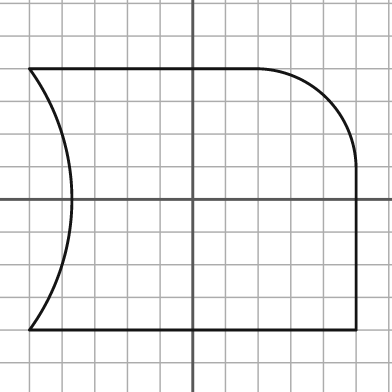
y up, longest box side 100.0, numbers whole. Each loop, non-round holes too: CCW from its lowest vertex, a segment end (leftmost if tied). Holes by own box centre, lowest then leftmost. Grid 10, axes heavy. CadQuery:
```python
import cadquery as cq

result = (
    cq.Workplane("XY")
    .moveTo(-50.0, -40.0)
    .lineTo(50.0, -40.0)
    .lineTo(50.0, 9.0)
    .threePointArc((41.0, 31.0), (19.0, 40.0))
    .lineTo(-50.0, 40.0)
    .threePointArc((-37.0, 0.0), (-50.0, -40.0))
    .close()
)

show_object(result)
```